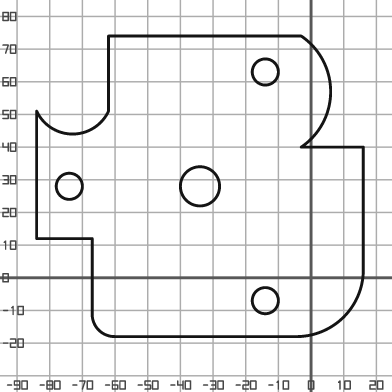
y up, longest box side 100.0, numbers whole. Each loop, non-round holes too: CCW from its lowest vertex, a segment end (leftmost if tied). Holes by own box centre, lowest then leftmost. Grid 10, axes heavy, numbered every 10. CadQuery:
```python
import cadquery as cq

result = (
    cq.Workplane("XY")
    .moveTo(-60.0, -18.0)
    .lineTo(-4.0, -18.0)
    .threePointArc((10.0, -12.0), (16.0, 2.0))
    .lineTo(16.0, 40.0)
    .lineTo(-3.0, 40.0)
    .threePointArc((6.0, 57.0), (-3.0, 74.0))
    .lineTo(-62.0, 74.0)
    .lineTo(-62.0, 51.0)
    .threePointArc((-73.0, 44.0), (-84.0, 51.0))
    .lineTo(-84.0, 12.0)
    .lineTo(-67.0, 12.0)
    .lineTo(-67.0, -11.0)
    .threePointArc((-65.0, -16.0), (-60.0, -18.0))
    .close()
    .moveTo(-14.0, -7.0)
    .circle(4.0)
    .moveTo(-74.0, 28.0)
    .circle(4.0)
    .moveTo(-34.0, 28.0)
    .circle(6.0)
    .moveTo(-14.0, 63.0)
    .circle(4.0)
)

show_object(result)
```